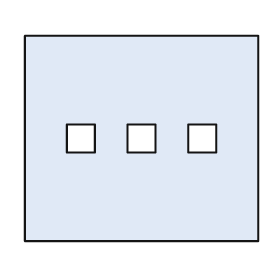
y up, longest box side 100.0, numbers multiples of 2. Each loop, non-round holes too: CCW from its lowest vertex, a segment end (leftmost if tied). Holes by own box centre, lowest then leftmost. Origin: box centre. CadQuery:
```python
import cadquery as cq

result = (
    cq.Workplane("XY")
    .moveTo(-50.0, -44.0)
    .lineTo(50.0, -44.0)
    .lineTo(50.0, 44.0)
    .lineTo(-50.0, 44.0)
    .close()
    .moveTo(-32.0, -6.0)
    .lineTo(-20.0, -6.0)
    .lineTo(-20.0, 6.0)
    .lineTo(-32.0, 6.0)
    .close()
    .moveTo(-6.0, -6.0)
    .lineTo(6.0, -6.0)
    .lineTo(6.0, 6.0)
    .lineTo(-6.0, 6.0)
    .close()
    .moveTo(20.0, -6.0)
    .lineTo(32.0, -6.0)
    .lineTo(32.0, 6.0)
    .lineTo(20.0, 6.0)
    .close()
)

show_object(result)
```